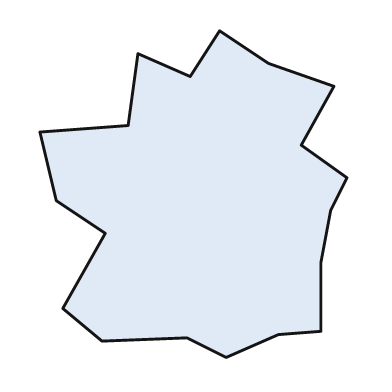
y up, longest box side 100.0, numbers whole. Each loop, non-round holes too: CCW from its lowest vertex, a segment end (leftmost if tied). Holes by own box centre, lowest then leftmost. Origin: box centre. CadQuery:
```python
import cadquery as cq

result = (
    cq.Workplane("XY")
    .moveTo(10.0, -50.0)
    .lineTo(26.0, -43.0)
    .lineTo(39.0, -42.0)
    .lineTo(39.0, -21.0)
    .lineTo(42.0, -5.0)
    .lineTo(47.0, 5.0)
    .lineTo(33.0, 15.0)
    .lineTo(43.0, 33.0)
    .lineTo(23.0, 40.0)
    .lineTo(8.0, 50.0)
    .lineTo(-1.0, 36.0)
    .lineTo(-17.0, 43.0)
    .lineTo(-20.0, 21.0)
    .lineTo(-47.0, 19.0)
    .lineTo(-42.0, -2.0)
    .lineTo(-27.0, -12.0)
    .lineTo(-40.0, -35.0)
    .lineTo(-28.0, -45.0)
    .lineTo(-2.0, -44.0)
    .close()
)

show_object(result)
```